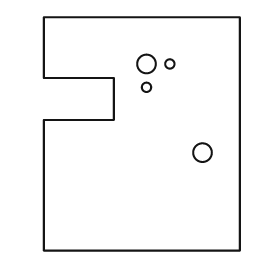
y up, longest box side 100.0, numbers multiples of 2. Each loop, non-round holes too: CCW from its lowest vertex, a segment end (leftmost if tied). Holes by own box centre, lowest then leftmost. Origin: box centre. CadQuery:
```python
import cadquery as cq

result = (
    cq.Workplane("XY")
    .moveTo(-42.0, -50.0)
    .lineTo(42.0, -50.0)
    .lineTo(42.0, 50.0)
    .lineTo(-42.0, 50.0)
    .lineTo(-42.0, 24.0)
    .lineTo(-12.0, 24.0)
    .lineTo(-12.0, 6.0)
    .lineTo(-42.0, 6.0)
    .close()
    .moveTo(26.0, -8.0)
    .circle(4.0)
    .moveTo(2.0, 20.0)
    .circle(2.0)
    .moveTo(2.0, 30.0)
    .circle(4.0)
    .moveTo(12.0, 30.0)
    .circle(2.0)
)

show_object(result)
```